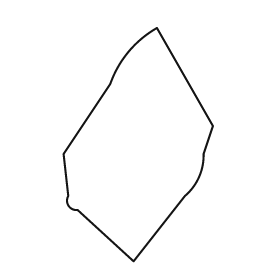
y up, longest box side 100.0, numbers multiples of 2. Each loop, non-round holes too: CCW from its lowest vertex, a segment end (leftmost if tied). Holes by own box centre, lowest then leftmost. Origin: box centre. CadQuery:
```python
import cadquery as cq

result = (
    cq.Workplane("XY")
    .moveTo(-2.0, -50.0)
    .lineTo(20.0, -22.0)
    .threePointArc((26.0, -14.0), (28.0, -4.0))
    .lineTo(32.0, 8.0)
    .lineTo(8.0, 50.0)
    .threePointArc((-4.0, 40.0), (-12.0, 26.0))
    .lineTo(-32.0, -4.0)
    .lineTo(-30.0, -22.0)
    .threePointArc((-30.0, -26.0), (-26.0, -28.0))
    .close()
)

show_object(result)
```